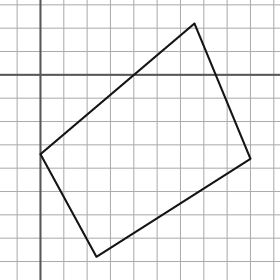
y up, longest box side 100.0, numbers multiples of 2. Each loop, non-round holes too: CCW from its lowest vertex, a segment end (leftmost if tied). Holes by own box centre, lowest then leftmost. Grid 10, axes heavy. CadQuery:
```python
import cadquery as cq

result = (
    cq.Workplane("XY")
    .moveTo(24.0, -78.0)
    .lineTo(90.0, -36.0)
    .lineTo(66.0, 22.0)
    .lineTo(0.0, -34.0)
    .close()
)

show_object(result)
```